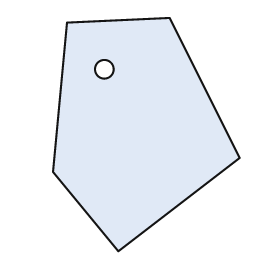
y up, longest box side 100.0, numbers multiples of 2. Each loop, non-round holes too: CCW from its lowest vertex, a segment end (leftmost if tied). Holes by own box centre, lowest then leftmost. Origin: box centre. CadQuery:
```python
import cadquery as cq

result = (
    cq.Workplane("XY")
    .moveTo(-12.0, -50.0)
    .lineTo(40.0, -10.0)
    .lineTo(10.0, 50.0)
    .lineTo(-34.0, 48.0)
    .lineTo(-40.0, -16.0)
    .close()
    .moveTo(-18.0, 28.0)
    .circle(4.0)
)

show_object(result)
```